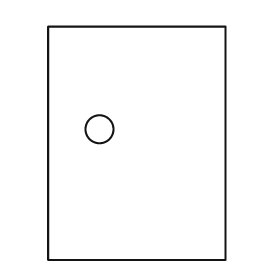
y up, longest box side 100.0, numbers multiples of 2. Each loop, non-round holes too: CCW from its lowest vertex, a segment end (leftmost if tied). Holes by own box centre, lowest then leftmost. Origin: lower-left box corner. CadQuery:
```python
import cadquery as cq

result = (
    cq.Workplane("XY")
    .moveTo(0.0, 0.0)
    .lineTo(76.0, 0.0)
    .lineTo(76.0, 100.0)
    .lineTo(0.0, 100.0)
    .close()
    .moveTo(22.0, 56.0)
    .circle(6.0)
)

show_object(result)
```